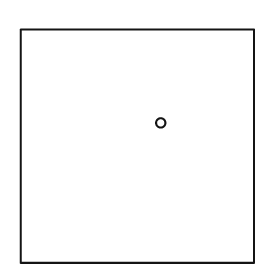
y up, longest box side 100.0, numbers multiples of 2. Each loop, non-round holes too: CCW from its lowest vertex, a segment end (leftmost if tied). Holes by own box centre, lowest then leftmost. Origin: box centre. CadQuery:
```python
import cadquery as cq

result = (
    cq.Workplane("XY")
    .moveTo(-50.0, -50.0)
    .lineTo(50.0, -50.0)
    .lineTo(50.0, 50.0)
    .lineTo(-50.0, 50.0)
    .close()
    .moveTo(10.0, 10.0)
    .circle(2.0)
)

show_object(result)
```